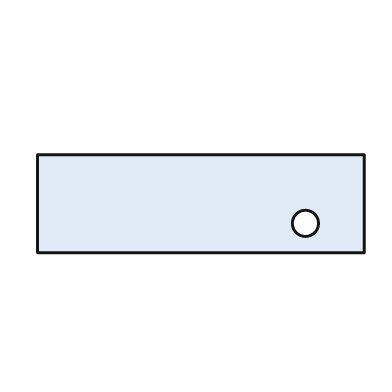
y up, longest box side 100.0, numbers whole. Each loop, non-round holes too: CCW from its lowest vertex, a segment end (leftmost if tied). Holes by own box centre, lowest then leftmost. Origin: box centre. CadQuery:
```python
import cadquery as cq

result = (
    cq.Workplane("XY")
    .moveTo(-50.0, -15.0)
    .lineTo(50.0, -15.0)
    .lineTo(50.0, 15.0)
    .lineTo(-50.0, 15.0)
    .close()
    .moveTo(32.0, -6.0)
    .circle(4.0)
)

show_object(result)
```